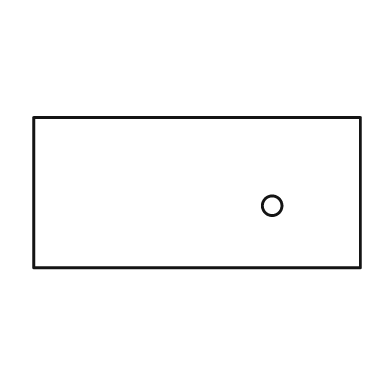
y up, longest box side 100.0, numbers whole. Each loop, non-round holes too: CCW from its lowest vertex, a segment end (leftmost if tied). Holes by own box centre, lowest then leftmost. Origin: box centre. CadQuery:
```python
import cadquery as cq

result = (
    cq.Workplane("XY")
    .moveTo(-50.0, -23.0)
    .lineTo(50.0, -23.0)
    .lineTo(50.0, 23.0)
    .lineTo(-50.0, 23.0)
    .close()
    .moveTo(23.0, -4.0)
    .circle(3.0)
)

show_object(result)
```